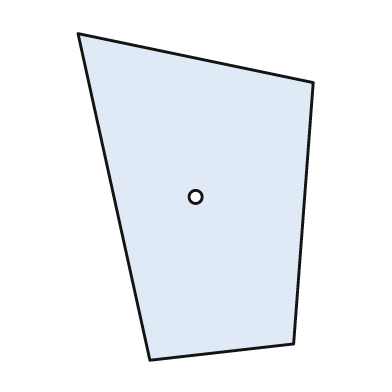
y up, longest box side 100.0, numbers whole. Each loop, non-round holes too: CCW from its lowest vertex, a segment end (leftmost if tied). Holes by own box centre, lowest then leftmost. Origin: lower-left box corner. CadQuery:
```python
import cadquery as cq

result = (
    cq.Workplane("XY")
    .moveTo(22.0, 0.0)
    .lineTo(66.0, 5.0)
    .lineTo(72.0, 85.0)
    .lineTo(0.0, 100.0)
    .close()
    .moveTo(36.0, 50.0)
    .circle(2.0)
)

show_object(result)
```